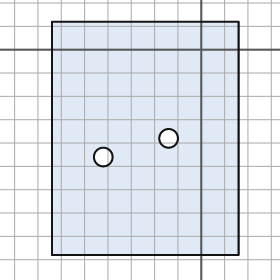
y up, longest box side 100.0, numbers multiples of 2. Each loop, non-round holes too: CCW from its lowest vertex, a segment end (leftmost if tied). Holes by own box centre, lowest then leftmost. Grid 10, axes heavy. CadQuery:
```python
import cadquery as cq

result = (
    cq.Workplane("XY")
    .moveTo(-64.0, -88.0)
    .lineTo(16.0, -88.0)
    .lineTo(16.0, 12.0)
    .lineTo(-64.0, 12.0)
    .close()
    .moveTo(-42.0, -46.0)
    .circle(4.0)
    .moveTo(-14.0, -38.0)
    .circle(4.0)
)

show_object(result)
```